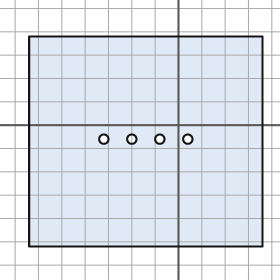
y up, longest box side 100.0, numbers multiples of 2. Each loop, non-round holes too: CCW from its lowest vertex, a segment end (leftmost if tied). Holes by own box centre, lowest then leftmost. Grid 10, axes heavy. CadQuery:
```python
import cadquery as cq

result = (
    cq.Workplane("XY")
    .moveTo(-64.0, -52.0)
    .lineTo(36.0, -52.0)
    .lineTo(36.0, 38.0)
    .lineTo(-64.0, 38.0)
    .close()
    .moveTo(-32.0, -6.0)
    .circle(2.0)
    .moveTo(-20.0, -6.0)
    .circle(2.0)
    .moveTo(-8.0, -6.0)
    .circle(2.0)
    .moveTo(4.0, -6.0)
    .circle(2.0)
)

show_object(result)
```